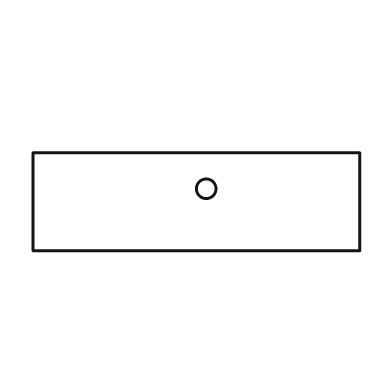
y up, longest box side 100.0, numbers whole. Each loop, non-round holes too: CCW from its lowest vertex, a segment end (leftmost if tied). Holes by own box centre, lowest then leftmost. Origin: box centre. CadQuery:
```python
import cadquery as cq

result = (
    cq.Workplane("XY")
    .moveTo(-50.0, -15.0)
    .lineTo(50.0, -15.0)
    .lineTo(50.0, 15.0)
    .lineTo(-50.0, 15.0)
    .close()
    .moveTo(3.0, 4.0)
    .circle(3.0)
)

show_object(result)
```